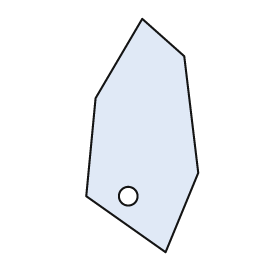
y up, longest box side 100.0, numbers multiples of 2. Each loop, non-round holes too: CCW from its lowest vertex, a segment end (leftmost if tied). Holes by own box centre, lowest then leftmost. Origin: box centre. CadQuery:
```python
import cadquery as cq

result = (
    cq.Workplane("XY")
    .moveTo(10.0, -50.0)
    .lineTo(24.0, -16.0)
    .lineTo(18.0, 34.0)
    .lineTo(0.0, 50.0)
    .lineTo(-20.0, 16.0)
    .lineTo(-24.0, -26.0)
    .close()
    .moveTo(-6.0, -26.0)
    .circle(4.0)
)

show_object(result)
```